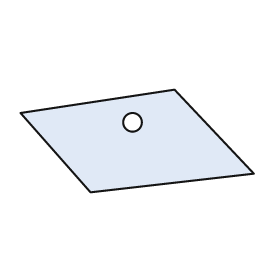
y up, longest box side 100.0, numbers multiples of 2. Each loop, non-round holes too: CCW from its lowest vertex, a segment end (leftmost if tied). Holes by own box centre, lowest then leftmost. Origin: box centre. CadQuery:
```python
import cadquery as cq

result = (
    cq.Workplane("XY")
    .moveTo(-20.0, -22.0)
    .lineTo(50.0, -14.0)
    .lineTo(16.0, 22.0)
    .lineTo(-50.0, 12.0)
    .close()
    .moveTo(-2.0, 8.0)
    .circle(4.0)
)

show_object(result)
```